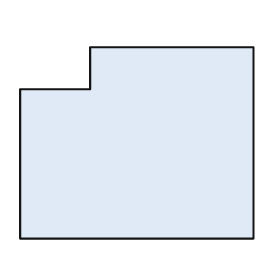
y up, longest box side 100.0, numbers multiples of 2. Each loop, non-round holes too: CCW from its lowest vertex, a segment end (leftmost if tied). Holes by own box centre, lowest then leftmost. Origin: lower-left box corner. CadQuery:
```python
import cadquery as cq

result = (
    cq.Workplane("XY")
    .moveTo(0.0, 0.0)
    .lineTo(100.0, 0.0)
    .lineTo(100.0, 82.0)
    .lineTo(30.0, 82.0)
    .lineTo(30.0, 64.0)
    .lineTo(0.0, 64.0)
    .close()
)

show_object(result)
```